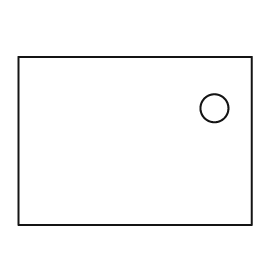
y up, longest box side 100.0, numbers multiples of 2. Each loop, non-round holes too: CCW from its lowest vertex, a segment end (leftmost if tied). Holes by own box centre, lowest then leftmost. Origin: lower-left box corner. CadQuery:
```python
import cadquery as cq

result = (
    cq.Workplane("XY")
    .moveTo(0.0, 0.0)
    .lineTo(100.0, 0.0)
    .lineTo(100.0, 72.0)
    .lineTo(0.0, 72.0)
    .close()
    .moveTo(84.0, 50.0)
    .circle(6.0)
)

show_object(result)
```